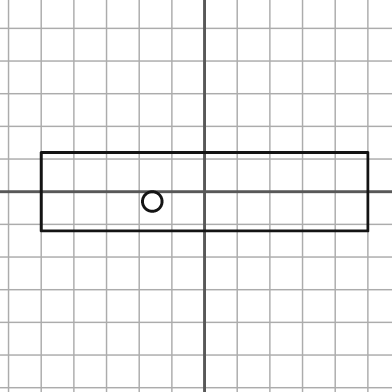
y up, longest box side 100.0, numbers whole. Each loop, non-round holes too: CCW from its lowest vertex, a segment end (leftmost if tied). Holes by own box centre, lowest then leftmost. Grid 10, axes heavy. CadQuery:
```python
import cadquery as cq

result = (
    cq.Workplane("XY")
    .moveTo(-50.0, -12.0)
    .lineTo(50.0, -12.0)
    .lineTo(50.0, 12.0)
    .lineTo(-50.0, 12.0)
    .close()
    .moveTo(-16.0, -3.0)
    .circle(3.0)
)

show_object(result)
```